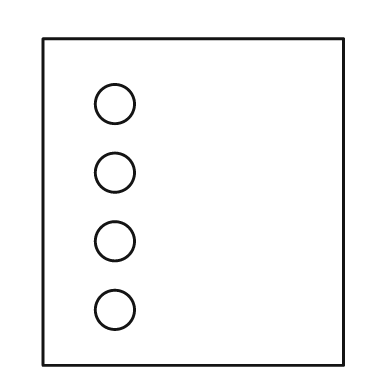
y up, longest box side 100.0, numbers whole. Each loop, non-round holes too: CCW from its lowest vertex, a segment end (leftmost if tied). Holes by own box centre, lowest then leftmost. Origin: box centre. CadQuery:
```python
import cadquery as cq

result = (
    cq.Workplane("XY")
    .moveTo(-46.0, -50.0)
    .lineTo(46.0, -50.0)
    .lineTo(46.0, 50.0)
    .lineTo(-46.0, 50.0)
    .close()
    .moveTo(-24.0, -33.0)
    .circle(6.0)
    .moveTo(-24.0, -12.0)
    .circle(6.0)
    .moveTo(-24.0, 9.0)
    .circle(6.0)
    .moveTo(-24.0, 30.0)
    .circle(6.0)
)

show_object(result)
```